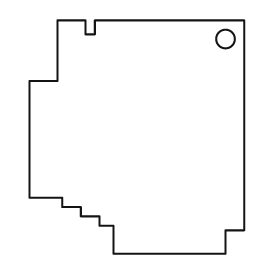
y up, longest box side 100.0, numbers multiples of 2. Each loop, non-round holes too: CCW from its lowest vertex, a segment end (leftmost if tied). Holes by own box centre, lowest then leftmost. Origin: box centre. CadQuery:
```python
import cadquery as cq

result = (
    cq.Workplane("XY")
    .moveTo(-10.0, -50.0)
    .lineTo(38.0, -50.0)
    .lineTo(38.0, -40.0)
    .lineTo(46.0, -40.0)
    .lineTo(46.0, 50.0)
    .lineTo(-18.0, 50.0)
    .lineTo(-18.0, 44.0)
    .lineTo(-22.0, 44.0)
    .lineTo(-22.0, 50.0)
    .lineTo(-34.0, 50.0)
    .lineTo(-34.0, 24.0)
    .lineTo(-46.0, 24.0)
    .lineTo(-46.0, -26.0)
    .lineTo(-32.0, -26.0)
    .lineTo(-32.0, -30.0)
    .lineTo(-24.0, -30.0)
    .lineTo(-24.0, -34.0)
    .lineTo(-16.0, -34.0)
    .lineTo(-16.0, -38.0)
    .lineTo(-10.0, -38.0)
    .close()
    .moveTo(38.0, 42.0)
    .circle(4.0)
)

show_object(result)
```